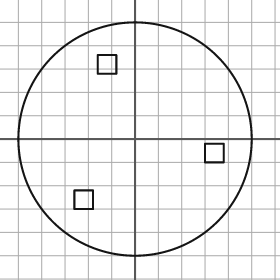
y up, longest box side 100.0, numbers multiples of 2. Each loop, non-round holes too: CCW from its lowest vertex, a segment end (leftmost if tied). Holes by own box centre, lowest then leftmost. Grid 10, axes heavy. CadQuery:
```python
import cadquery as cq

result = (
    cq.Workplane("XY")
    .moveTo(0.0, 0.0)
    .circle(50.0)
    .moveTo(-26.0, -30.0)
    .lineTo(-18.0, -30.0)
    .lineTo(-18.0, -22.0)
    .lineTo(-26.0, -22.0)
    .close()
    .moveTo(30.0, -10.0)
    .lineTo(38.0, -10.0)
    .lineTo(38.0, -2.0)
    .lineTo(30.0, -2.0)
    .close()
    .moveTo(-16.0, 28.0)
    .lineTo(-8.0, 28.0)
    .lineTo(-8.0, 36.0)
    .lineTo(-16.0, 36.0)
    .close()
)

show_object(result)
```